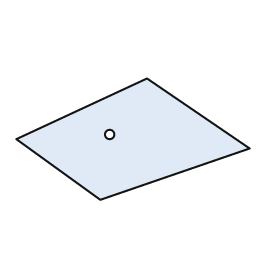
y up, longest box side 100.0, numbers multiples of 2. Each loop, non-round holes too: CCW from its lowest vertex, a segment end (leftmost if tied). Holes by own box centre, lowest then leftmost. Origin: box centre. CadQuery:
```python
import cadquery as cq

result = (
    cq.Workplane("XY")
    .moveTo(-14.0, -26.0)
    .lineTo(50.0, -4.0)
    .lineTo(6.0, 26.0)
    .lineTo(-50.0, 0.0)
    .close()
    .moveTo(-10.0, 2.0)
    .circle(2.0)
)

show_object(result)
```